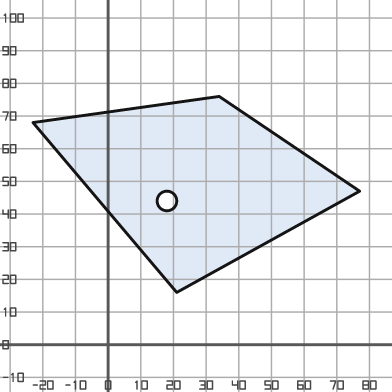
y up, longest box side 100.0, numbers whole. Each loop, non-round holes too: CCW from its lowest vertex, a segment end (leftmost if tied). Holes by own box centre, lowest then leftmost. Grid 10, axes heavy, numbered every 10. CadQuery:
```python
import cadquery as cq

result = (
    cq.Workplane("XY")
    .moveTo(21.0, 16.0)
    .lineTo(77.0, 47.0)
    .lineTo(34.0, 76.0)
    .lineTo(-23.0, 68.0)
    .close()
    .moveTo(18.0, 44.0)
    .circle(3.0)
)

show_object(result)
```